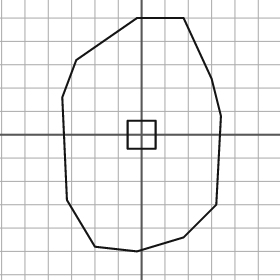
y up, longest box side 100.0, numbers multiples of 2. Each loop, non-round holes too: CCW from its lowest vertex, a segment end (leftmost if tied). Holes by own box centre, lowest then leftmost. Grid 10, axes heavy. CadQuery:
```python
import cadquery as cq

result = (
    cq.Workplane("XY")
    .moveTo(-2.0, -50.0)
    .lineTo(18.0, -44.0)
    .lineTo(32.0, -30.0)
    .lineTo(34.0, 8.0)
    .lineTo(30.0, 24.0)
    .lineTo(18.0, 50.0)
    .lineTo(-2.0, 50.0)
    .lineTo(-28.0, 32.0)
    .lineTo(-34.0, 16.0)
    .lineTo(-32.0, -28.0)
    .lineTo(-20.0, -48.0)
    .close()
    .moveTo(-6.0, -6.0)
    .lineTo(6.0, -6.0)
    .lineTo(6.0, 6.0)
    .lineTo(-6.0, 6.0)
    .close()
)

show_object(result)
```